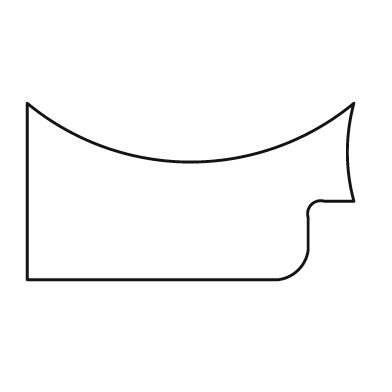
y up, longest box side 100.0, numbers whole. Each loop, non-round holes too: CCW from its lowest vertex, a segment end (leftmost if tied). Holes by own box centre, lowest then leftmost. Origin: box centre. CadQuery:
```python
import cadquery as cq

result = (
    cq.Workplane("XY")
    .moveTo(-50.0, -27.0)
    .lineTo(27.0, -27.0)
    .threePointArc((33.0, -24.0), (36.0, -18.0))
    .lineTo(36.0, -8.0)
    .threePointArc((37.0, -4.0), (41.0, -3.0))
    .lineTo(50.0, -3.0)
    .threePointArc((48.0, 12.0), (50.0, 27.0))
    .threePointArc((0.0, 9.0), (-50.0, 27.0))
    .close()
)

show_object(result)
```